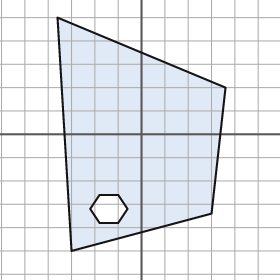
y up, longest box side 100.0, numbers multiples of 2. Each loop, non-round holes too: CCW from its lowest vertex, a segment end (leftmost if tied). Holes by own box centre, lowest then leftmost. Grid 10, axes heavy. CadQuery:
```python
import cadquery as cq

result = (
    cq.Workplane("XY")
    .moveTo(-30.0, -50.0)
    .lineTo(30.0, -34.0)
    .lineTo(36.0, 20.0)
    .lineTo(-36.0, 50.0)
    .close()
    .moveTo(-18.0, -38.0)
    .lineTo(-10.0, -38.0)
    .lineTo(-6.0, -32.0)
    .lineTo(-10.0, -26.0)
    .lineTo(-18.0, -26.0)
    .lineTo(-22.0, -32.0)
    .close()
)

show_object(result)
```